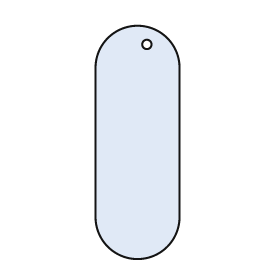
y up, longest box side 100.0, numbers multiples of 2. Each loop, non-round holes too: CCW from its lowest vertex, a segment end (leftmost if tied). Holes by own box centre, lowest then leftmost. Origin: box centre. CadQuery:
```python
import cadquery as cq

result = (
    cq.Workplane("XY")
    .moveTo(-18.0, -32.0)
    .threePointArc((0.0, -50.0), (18.0, -32.0))
    .lineTo(18.0, 32.0)
    .threePointArc((0.0, 50.0), (-18.0, 32.0))
    .close()
    .moveTo(4.0, 42.0)
    .circle(2.0)
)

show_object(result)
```